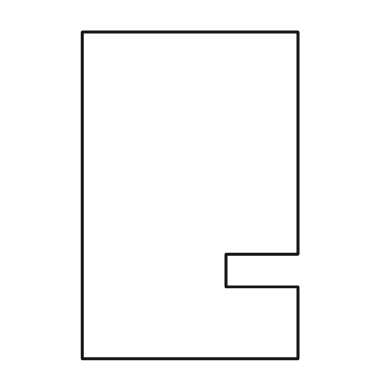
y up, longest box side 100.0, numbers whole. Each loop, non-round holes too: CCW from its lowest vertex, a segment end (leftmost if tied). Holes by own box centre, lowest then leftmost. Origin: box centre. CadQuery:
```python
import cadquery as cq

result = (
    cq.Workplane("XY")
    .moveTo(-33.0, -50.0)
    .lineTo(33.0, -50.0)
    .lineTo(33.0, -28.0)
    .lineTo(11.0, -28.0)
    .lineTo(11.0, -18.0)
    .lineTo(33.0, -18.0)
    .lineTo(33.0, 50.0)
    .lineTo(-33.0, 50.0)
    .close()
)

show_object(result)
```